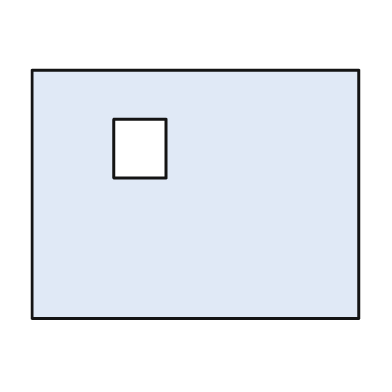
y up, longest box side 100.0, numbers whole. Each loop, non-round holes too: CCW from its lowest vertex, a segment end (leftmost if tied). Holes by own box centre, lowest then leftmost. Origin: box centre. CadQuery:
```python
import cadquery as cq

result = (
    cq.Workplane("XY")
    .moveTo(-50.0, -38.0)
    .lineTo(50.0, -38.0)
    .lineTo(50.0, 38.0)
    .lineTo(-50.0, 38.0)
    .close()
    .moveTo(-25.0, 5.0)
    .lineTo(-9.0, 5.0)
    .lineTo(-9.0, 23.0)
    .lineTo(-25.0, 23.0)
    .close()
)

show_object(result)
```